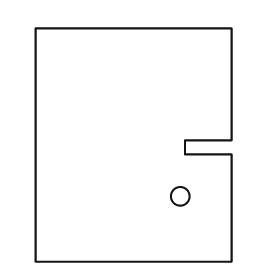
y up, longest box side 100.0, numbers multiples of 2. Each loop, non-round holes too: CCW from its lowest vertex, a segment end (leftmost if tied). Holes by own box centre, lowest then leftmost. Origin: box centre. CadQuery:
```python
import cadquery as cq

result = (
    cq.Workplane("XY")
    .moveTo(-42.0, -50.0)
    .lineTo(42.0, -50.0)
    .lineTo(42.0, -4.0)
    .lineTo(22.0, -4.0)
    .lineTo(22.0, 2.0)
    .lineTo(42.0, 2.0)
    .lineTo(42.0, 50.0)
    .lineTo(-42.0, 50.0)
    .close()
    .moveTo(20.0, -22.0)
    .circle(4.0)
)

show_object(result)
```